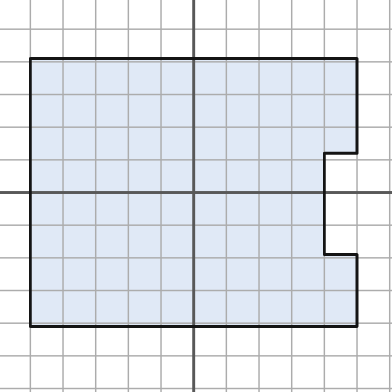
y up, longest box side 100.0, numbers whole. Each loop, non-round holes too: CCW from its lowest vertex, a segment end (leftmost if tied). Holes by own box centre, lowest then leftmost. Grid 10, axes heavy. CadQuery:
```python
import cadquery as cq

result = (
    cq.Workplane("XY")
    .moveTo(-50.0, -41.0)
    .lineTo(50.0, -41.0)
    .lineTo(50.0, -19.0)
    .lineTo(40.0, -19.0)
    .lineTo(40.0, 12.0)
    .lineTo(50.0, 12.0)
    .lineTo(50.0, 41.0)
    .lineTo(-50.0, 41.0)
    .close()
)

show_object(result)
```